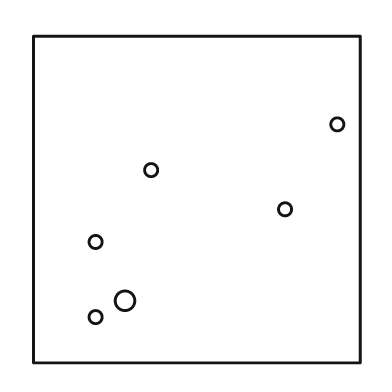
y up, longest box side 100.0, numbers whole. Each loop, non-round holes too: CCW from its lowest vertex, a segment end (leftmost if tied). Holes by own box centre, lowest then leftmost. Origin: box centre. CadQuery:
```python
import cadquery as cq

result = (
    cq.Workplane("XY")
    .moveTo(-50.0, -50.0)
    .lineTo(50.0, -50.0)
    .lineTo(50.0, 50.0)
    .lineTo(-50.0, 50.0)
    .close()
    .moveTo(-31.0, -36.0)
    .circle(2.0)
    .moveTo(-22.0, -31.0)
    .circle(3.0)
    .moveTo(-31.0, -13.0)
    .circle(2.0)
    .moveTo(27.0, -3.0)
    .circle(2.0)
    .moveTo(-14.0, 9.0)
    .circle(2.0)
    .moveTo(43.0, 23.0)
    .circle(2.0)
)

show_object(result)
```